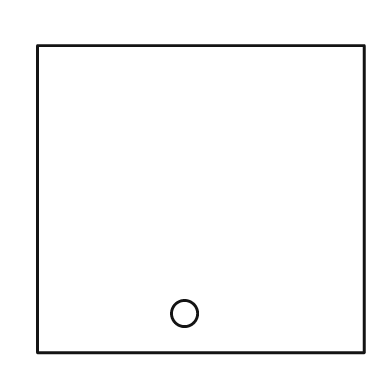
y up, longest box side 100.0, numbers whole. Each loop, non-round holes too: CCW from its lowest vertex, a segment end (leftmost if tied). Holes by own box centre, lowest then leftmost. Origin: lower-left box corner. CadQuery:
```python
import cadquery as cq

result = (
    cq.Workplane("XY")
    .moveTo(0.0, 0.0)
    .lineTo(100.0, 0.0)
    .lineTo(100.0, 94.0)
    .lineTo(0.0, 94.0)
    .close()
    .moveTo(45.0, 12.0)
    .circle(4.0)
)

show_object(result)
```